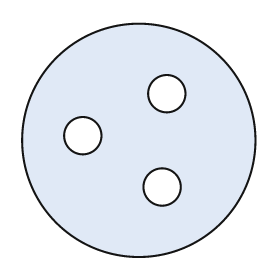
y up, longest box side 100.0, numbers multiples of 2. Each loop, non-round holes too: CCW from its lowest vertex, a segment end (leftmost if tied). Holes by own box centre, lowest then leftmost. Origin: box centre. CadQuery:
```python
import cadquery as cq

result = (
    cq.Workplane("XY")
    .moveTo(0.0, 0.0)
    .circle(50.0)
    .moveTo(10.0, -20.0)
    .circle(8.0)
    .moveTo(-24.0, 2.0)
    .circle(8.0)
    .moveTo(12.0, 20.0)
    .circle(8.0)
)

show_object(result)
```